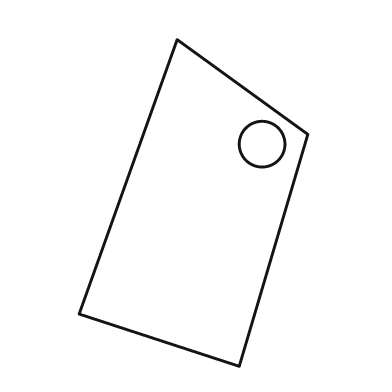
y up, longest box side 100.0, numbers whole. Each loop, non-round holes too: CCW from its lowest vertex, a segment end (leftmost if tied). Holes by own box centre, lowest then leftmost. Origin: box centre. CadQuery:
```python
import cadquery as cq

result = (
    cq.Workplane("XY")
    .moveTo(14.0, -50.0)
    .lineTo(35.0, 21.0)
    .lineTo(-5.0, 50.0)
    .lineTo(-35.0, -34.0)
    .close()
    .moveTo(21.0, 18.0)
    .circle(7.0)
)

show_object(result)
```